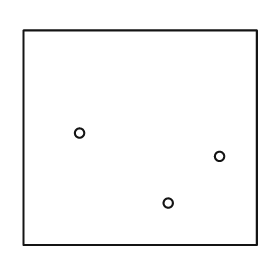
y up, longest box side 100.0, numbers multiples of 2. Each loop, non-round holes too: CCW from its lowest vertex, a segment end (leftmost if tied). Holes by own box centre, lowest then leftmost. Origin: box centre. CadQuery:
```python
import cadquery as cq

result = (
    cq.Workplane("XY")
    .moveTo(-50.0, -46.0)
    .lineTo(50.0, -46.0)
    .lineTo(50.0, 46.0)
    .lineTo(-50.0, 46.0)
    .close()
    .moveTo(12.0, -28.0)
    .circle(2.0)
    .moveTo(34.0, -8.0)
    .circle(2.0)
    .moveTo(-26.0, 2.0)
    .circle(2.0)
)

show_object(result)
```